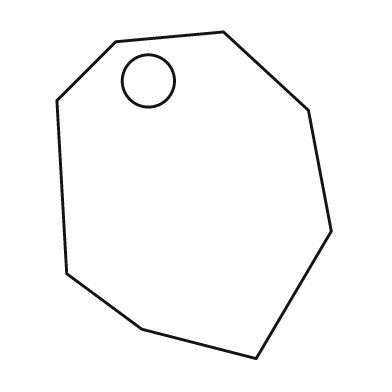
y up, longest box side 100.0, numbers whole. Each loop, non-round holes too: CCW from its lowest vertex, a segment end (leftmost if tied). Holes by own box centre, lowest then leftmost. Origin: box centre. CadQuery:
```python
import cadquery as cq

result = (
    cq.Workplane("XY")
    .moveTo(19.0, -50.0)
    .lineTo(42.0, -11.0)
    .lineTo(35.0, 26.0)
    .lineTo(9.0, 50.0)
    .lineTo(-24.0, 47.0)
    .lineTo(-42.0, 29.0)
    .lineTo(-39.0, -24.0)
    .lineTo(-16.0, -41.0)
    .close()
    .moveTo(-14.0, 35.0)
    .circle(8.0)
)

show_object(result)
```